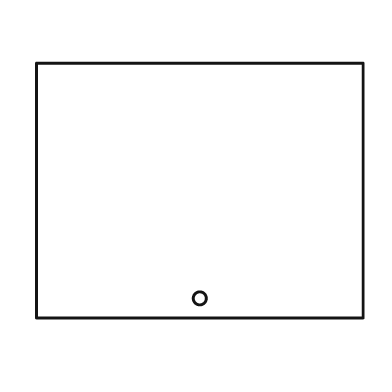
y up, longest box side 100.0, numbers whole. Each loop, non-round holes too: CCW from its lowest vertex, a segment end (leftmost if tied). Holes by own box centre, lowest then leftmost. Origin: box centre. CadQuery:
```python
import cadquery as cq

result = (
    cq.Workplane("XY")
    .moveTo(-50.0, -39.0)
    .lineTo(50.0, -39.0)
    .lineTo(50.0, 39.0)
    .lineTo(-50.0, 39.0)
    .close()
    .moveTo(0.0, -33.0)
    .circle(2.0)
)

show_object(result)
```